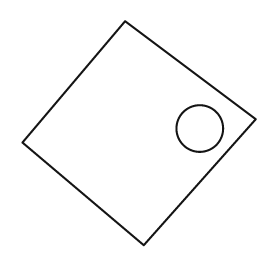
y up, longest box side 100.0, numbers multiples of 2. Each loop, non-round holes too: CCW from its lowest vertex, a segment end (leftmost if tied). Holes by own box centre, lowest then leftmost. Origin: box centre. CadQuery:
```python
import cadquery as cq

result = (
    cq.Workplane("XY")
    .moveTo(2.0, -48.0)
    .lineTo(50.0, 6.0)
    .lineTo(-6.0, 48.0)
    .lineTo(-50.0, -4.0)
    .close()
    .moveTo(26.0, 2.0)
    .circle(10.0)
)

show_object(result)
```